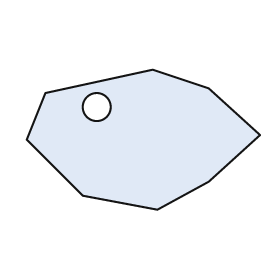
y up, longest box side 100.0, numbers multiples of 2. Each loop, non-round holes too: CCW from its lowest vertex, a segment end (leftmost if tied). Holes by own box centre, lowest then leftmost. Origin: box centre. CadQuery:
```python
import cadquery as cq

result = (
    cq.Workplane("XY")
    .moveTo(6.0, -30.0)
    .lineTo(28.0, -18.0)
    .lineTo(50.0, 2.0)
    .lineTo(28.0, 22.0)
    .lineTo(4.0, 30.0)
    .lineTo(-42.0, 20.0)
    .lineTo(-50.0, 0.0)
    .lineTo(-26.0, -24.0)
    .close()
    .moveTo(-20.0, 14.0)
    .circle(6.0)
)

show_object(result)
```